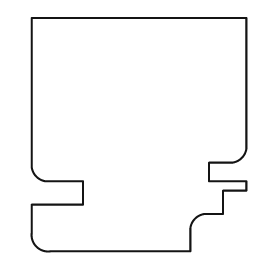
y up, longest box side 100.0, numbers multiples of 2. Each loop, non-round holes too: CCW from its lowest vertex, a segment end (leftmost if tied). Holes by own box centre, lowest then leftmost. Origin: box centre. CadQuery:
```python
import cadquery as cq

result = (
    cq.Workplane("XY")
    .moveTo(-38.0, -50.0)
    .lineTo(22.0, -50.0)
    .lineTo(22.0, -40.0)
    .threePointArc((24.0, -36.0), (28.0, -34.0))
    .lineTo(36.0, -34.0)
    .lineTo(36.0, -24.0)
    .lineTo(46.0, -24.0)
    .lineTo(46.0, -20.0)
    .lineTo(30.0, -20.0)
    .lineTo(30.0, -12.0)
    .lineTo(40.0, -12.0)
    .threePointArc((44.0, -10.0), (46.0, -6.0))
    .lineTo(46.0, 50.0)
    .lineTo(-46.0, 50.0)
    .lineTo(-46.0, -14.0)
    .threePointArc((-44.0, -18.0), (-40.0, -20.0))
    .lineTo(-24.0, -20.0)
    .lineTo(-24.0, -30.0)
    .lineTo(-46.0, -30.0)
    .lineTo(-46.0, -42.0)
    .threePointArc((-44.0, -48.0), (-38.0, -50.0))
    .close()
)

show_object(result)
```